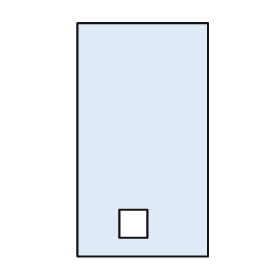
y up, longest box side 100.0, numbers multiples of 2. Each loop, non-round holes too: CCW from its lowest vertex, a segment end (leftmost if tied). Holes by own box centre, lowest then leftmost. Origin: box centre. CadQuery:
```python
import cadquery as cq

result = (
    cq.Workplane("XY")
    .moveTo(-28.0, -50.0)
    .lineTo(28.0, -50.0)
    .lineTo(28.0, 50.0)
    .lineTo(-28.0, 50.0)
    .close()
    .moveTo(-10.0, -42.0)
    .lineTo(2.0, -42.0)
    .lineTo(2.0, -30.0)
    .lineTo(-10.0, -30.0)
    .close()
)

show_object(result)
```